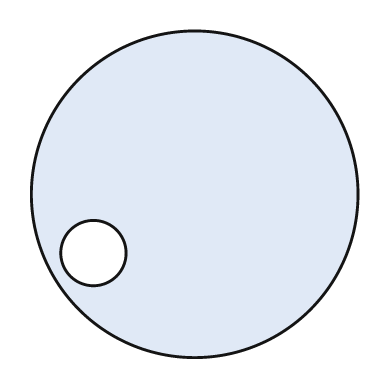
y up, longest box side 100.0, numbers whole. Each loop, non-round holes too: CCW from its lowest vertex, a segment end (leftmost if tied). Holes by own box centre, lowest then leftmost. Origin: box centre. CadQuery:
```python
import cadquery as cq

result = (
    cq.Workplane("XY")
    .moveTo(0.0, 0.0)
    .circle(50.0)
    .moveTo(-31.0, -18.0)
    .circle(10.0)
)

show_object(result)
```